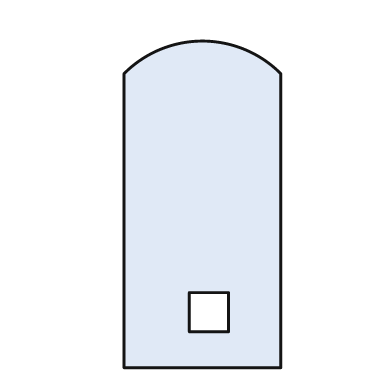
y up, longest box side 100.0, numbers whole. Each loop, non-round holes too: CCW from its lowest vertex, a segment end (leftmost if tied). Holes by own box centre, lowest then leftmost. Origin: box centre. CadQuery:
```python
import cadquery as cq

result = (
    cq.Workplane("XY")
    .moveTo(-24.0, -50.0)
    .lineTo(24.0, -50.0)
    .lineTo(24.0, 40.0)
    .threePointArc((0.0, 50.0), (-24.0, 40.0))
    .close()
    .moveTo(-4.0, -39.0)
    .lineTo(8.0, -39.0)
    .lineTo(8.0, -27.0)
    .lineTo(-4.0, -27.0)
    .close()
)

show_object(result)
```